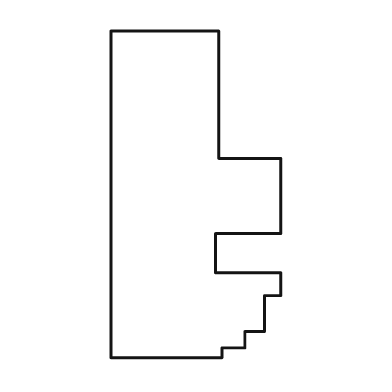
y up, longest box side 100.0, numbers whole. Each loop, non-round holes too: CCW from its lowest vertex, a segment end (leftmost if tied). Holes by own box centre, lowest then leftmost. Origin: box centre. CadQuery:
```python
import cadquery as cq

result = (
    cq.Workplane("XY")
    .moveTo(-26.0, -50.0)
    .lineTo(8.0, -50.0)
    .lineTo(8.0, -47.0)
    .lineTo(15.0, -47.0)
    .lineTo(15.0, -42.0)
    .lineTo(21.0, -42.0)
    .lineTo(21.0, -31.0)
    .lineTo(26.0, -31.0)
    .lineTo(26.0, -24.0)
    .lineTo(6.0, -24.0)
    .lineTo(6.0, -12.0)
    .lineTo(26.0, -12.0)
    .lineTo(26.0, 11.0)
    .lineTo(7.0, 11.0)
    .lineTo(7.0, 50.0)
    .lineTo(-26.0, 50.0)
    .close()
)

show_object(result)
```